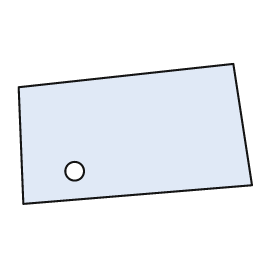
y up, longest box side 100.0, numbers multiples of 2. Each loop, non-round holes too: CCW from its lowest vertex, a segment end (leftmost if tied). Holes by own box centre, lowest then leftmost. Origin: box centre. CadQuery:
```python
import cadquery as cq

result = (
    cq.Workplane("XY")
    .moveTo(-48.0, -30.0)
    .lineTo(50.0, -22.0)
    .lineTo(42.0, 30.0)
    .lineTo(-50.0, 20.0)
    .close()
    .moveTo(-26.0, -16.0)
    .circle(4.0)
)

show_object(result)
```